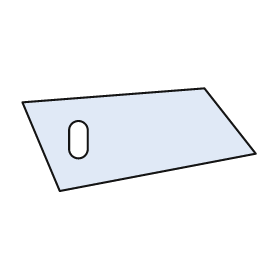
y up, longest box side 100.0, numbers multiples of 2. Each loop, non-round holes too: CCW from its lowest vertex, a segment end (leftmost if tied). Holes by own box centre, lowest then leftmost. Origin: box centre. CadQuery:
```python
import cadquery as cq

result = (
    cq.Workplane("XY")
    .moveTo(-34.0, -22.0)
    .lineTo(50.0, -6.0)
    .lineTo(28.0, 22.0)
    .lineTo(-50.0, 16.0)
    .close()
    .moveTo(-30.0, -4.0)
    .threePointArc((-26.0, -8.0), (-22.0, -4.0))
    .lineTo(-22.0, 4.0)
    .threePointArc((-26.0, 8.0), (-30.0, 4.0))
    .close()
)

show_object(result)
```